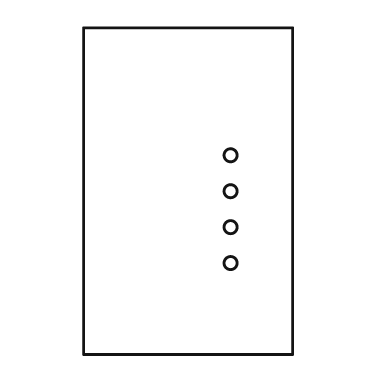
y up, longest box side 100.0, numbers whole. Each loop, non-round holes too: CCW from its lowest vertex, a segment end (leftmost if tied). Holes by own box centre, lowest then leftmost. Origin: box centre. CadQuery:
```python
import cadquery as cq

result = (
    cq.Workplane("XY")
    .moveTo(-32.0, -50.0)
    .lineTo(32.0, -50.0)
    .lineTo(32.0, 50.0)
    .lineTo(-32.0, 50.0)
    .close()
    .moveTo(13.0, -22.0)
    .circle(2.0)
    .moveTo(13.0, -11.0)
    .circle(2.0)
    .moveTo(13.0, 0.0)
    .circle(2.0)
    .moveTo(13.0, 11.0)
    .circle(2.0)
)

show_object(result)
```